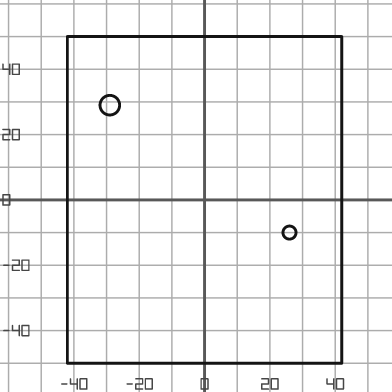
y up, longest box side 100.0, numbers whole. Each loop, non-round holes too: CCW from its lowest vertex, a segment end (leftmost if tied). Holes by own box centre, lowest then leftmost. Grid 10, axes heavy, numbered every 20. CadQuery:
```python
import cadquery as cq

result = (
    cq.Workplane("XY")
    .moveTo(-42.0, -50.0)
    .lineTo(42.0, -50.0)
    .lineTo(42.0, 50.0)
    .lineTo(-42.0, 50.0)
    .close()
    .moveTo(26.0, -10.0)
    .circle(2.0)
    .moveTo(-29.0, 29.0)
    .circle(3.0)
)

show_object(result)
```